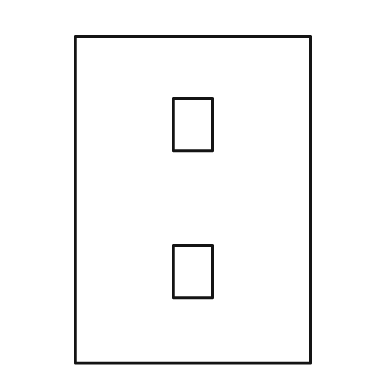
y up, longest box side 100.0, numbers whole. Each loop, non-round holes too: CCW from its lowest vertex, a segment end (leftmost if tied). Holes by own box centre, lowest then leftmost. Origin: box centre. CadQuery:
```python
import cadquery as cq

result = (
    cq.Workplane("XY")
    .moveTo(-36.0, -50.0)
    .lineTo(36.0, -50.0)
    .lineTo(36.0, 50.0)
    .lineTo(-36.0, 50.0)
    .close()
    .moveTo(-6.0, -30.0)
    .lineTo(6.0, -30.0)
    .lineTo(6.0, -14.0)
    .lineTo(-6.0, -14.0)
    .close()
    .moveTo(-6.0, 15.0)
    .lineTo(6.0, 15.0)
    .lineTo(6.0, 31.0)
    .lineTo(-6.0, 31.0)
    .close()
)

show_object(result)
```